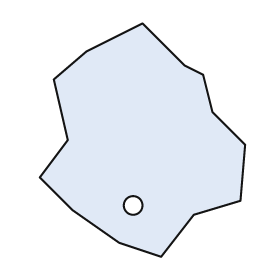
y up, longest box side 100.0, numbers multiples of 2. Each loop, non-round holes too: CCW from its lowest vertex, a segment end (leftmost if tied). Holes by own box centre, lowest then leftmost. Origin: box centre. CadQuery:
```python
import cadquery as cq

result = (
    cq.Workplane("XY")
    .moveTo(8.0, -50.0)
    .lineTo(22.0, -32.0)
    .lineTo(42.0, -26.0)
    .lineTo(44.0, -2.0)
    .lineTo(30.0, 12.0)
    .lineTo(26.0, 28.0)
    .lineTo(18.0, 32.0)
    .lineTo(0.0, 50.0)
    .lineTo(-24.0, 38.0)
    .lineTo(-38.0, 26.0)
    .lineTo(-32.0, 0.0)
    .lineTo(-44.0, -16.0)
    .lineTo(-30.0, -30.0)
    .lineTo(-10.0, -44.0)
    .close()
    .moveTo(-4.0, -28.0)
    .circle(4.0)
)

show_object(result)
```